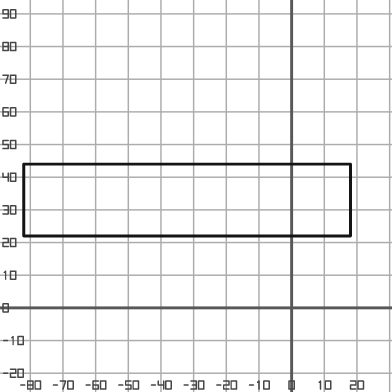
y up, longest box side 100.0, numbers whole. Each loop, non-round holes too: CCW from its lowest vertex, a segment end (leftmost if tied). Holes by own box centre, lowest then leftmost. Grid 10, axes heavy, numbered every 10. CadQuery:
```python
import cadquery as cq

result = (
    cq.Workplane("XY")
    .moveTo(-82.0, 22.0)
    .lineTo(18.0, 22.0)
    .lineTo(18.0, 44.0)
    .lineTo(-82.0, 44.0)
    .close()
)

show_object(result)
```